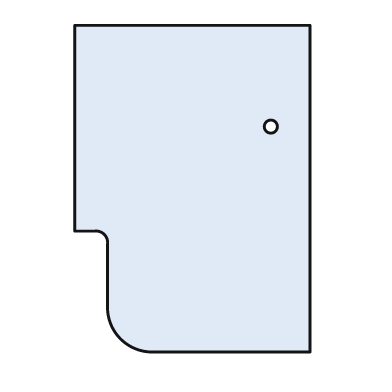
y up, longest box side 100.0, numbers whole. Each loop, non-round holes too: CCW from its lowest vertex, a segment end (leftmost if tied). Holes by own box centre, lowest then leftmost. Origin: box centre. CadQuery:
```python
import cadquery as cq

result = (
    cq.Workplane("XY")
    .moveTo(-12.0, -50.0)
    .lineTo(36.0, -50.0)
    .lineTo(36.0, 50.0)
    .lineTo(-36.0, 50.0)
    .lineTo(-36.0, -13.0)
    .lineTo(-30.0, -13.0)
    .threePointArc((-27.0, -14.0), (-26.0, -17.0))
    .lineTo(-26.0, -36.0)
    .threePointArc((-22.0, -46.0), (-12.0, -50.0))
    .close()
    .moveTo(24.0, 19.0)
    .circle(2.0)
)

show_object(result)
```